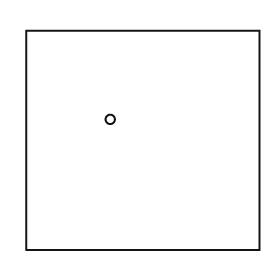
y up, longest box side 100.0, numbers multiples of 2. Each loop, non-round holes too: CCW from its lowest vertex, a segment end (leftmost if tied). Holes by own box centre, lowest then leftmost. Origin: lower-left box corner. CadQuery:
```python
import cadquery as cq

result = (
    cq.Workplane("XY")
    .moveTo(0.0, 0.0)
    .lineTo(100.0, 0.0)
    .lineTo(100.0, 94.0)
    .lineTo(0.0, 94.0)
    .close()
    .moveTo(36.0, 56.0)
    .circle(2.0)
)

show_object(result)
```